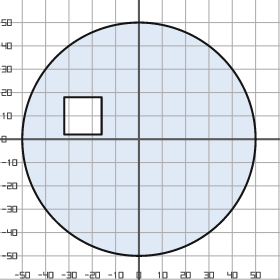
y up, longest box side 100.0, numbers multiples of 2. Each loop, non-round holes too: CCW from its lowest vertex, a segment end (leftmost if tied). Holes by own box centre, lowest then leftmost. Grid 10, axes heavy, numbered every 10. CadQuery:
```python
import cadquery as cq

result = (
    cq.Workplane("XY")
    .moveTo(0.0, 0.0)
    .circle(50.0)
    .moveTo(-32.0, 2.0)
    .lineTo(-16.0, 2.0)
    .lineTo(-16.0, 18.0)
    .lineTo(-32.0, 18.0)
    .close()
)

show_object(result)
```